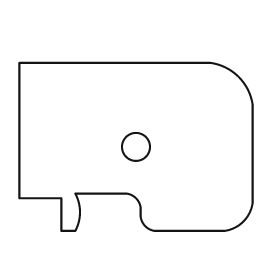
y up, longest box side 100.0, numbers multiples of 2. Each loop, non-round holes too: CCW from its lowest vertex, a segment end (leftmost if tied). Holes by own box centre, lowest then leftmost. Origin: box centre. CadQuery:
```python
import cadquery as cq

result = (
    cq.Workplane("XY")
    .moveTo(-32.0, -36.0)
    .lineTo(-26.0, -36.0)
    .threePointArc((-24.0, -28.0), (-26.0, -20.0))
    .lineTo(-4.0, -20.0)
    .threePointArc((0.0, -22.0), (2.0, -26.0))
    .lineTo(2.0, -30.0)
    .threePointArc((4.0, -34.0), (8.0, -36.0))
    .lineTo(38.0, -36.0)
    .threePointArc((46.0, -32.0), (50.0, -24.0))
    .lineTo(50.0, 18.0)
    .threePointArc((44.0, 30.0), (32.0, 36.0))
    .lineTo(-50.0, 36.0)
    .lineTo(-50.0, -22.0)
    .lineTo(-32.0, -22.0)
    .close()
    .moveTo(0.0, 0.0)
    .circle(6.0)
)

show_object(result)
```